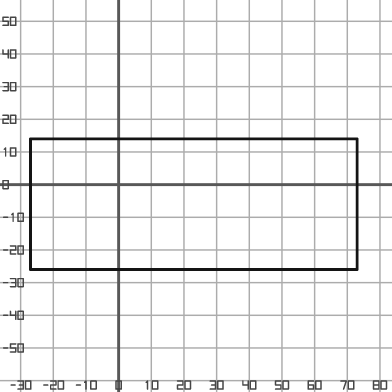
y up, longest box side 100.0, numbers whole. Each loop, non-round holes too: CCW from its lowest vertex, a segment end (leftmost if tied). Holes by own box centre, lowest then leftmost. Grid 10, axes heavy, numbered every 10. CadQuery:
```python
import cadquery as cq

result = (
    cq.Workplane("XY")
    .moveTo(-27.0, -26.0)
    .lineTo(73.0, -26.0)
    .lineTo(73.0, 14.0)
    .lineTo(-27.0, 14.0)
    .close()
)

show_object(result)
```